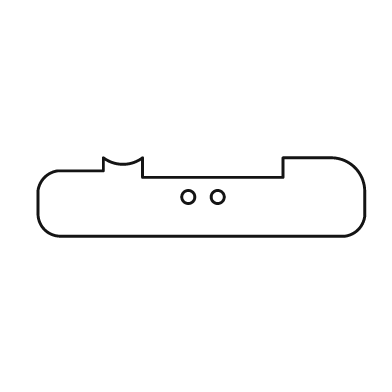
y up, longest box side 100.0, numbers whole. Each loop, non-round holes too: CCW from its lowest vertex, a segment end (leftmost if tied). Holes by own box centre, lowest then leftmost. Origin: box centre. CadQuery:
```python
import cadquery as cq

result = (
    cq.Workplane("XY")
    .moveTo(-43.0, -12.0)
    .lineTo(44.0, -12.0)
    .threePointArc((48.0, -10.0), (50.0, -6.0))
    .lineTo(50.0, 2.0)
    .threePointArc((47.0, 9.0), (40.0, 12.0))
    .lineTo(25.0, 12.0)
    .lineTo(25.0, 6.0)
    .lineTo(-18.0, 6.0)
    .lineTo(-18.0, 12.0)
    .threePointArc((-24.0, 10.0), (-30.0, 12.0))
    .lineTo(-30.0, 8.0)
    .lineTo(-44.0, 8.0)
    .threePointArc((-48.0, 6.0), (-50.0, 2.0))
    .lineTo(-50.0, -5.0)
    .threePointArc((-48.0, -10.0), (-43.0, -12.0))
    .close()
    .moveTo(-4.0, 0.0)
    .circle(2.0)
    .moveTo(5.0, 0.0)
    .circle(2.0)
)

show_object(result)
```